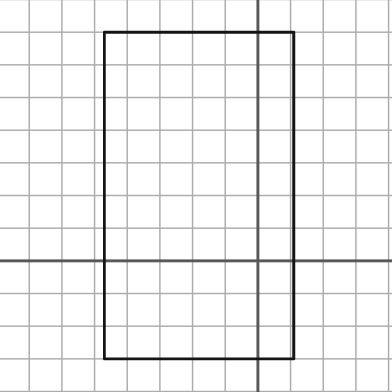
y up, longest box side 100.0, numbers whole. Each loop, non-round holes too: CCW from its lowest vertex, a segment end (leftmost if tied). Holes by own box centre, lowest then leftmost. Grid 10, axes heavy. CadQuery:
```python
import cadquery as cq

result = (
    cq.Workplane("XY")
    .moveTo(-47.0, -30.0)
    .lineTo(11.0, -30.0)
    .lineTo(11.0, 70.0)
    .lineTo(-47.0, 70.0)
    .close()
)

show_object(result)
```